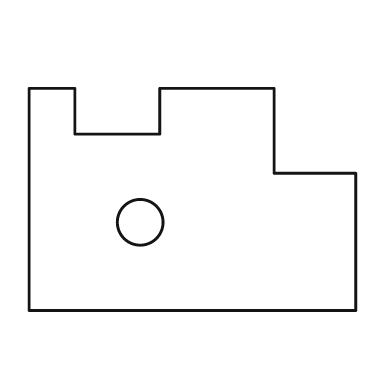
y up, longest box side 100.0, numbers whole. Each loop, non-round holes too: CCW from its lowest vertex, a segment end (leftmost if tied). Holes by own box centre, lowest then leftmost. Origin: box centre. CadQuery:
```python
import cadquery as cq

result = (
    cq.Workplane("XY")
    .moveTo(-50.0, -34.0)
    .lineTo(50.0, -34.0)
    .lineTo(50.0, 8.0)
    .lineTo(25.0, 8.0)
    .lineTo(25.0, 34.0)
    .lineTo(-10.0, 34.0)
    .lineTo(-10.0, 20.0)
    .lineTo(-36.0, 20.0)
    .lineTo(-36.0, 34.0)
    .lineTo(-50.0, 34.0)
    .close()
    .moveTo(-16.0, -7.0)
    .circle(7.0)
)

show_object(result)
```